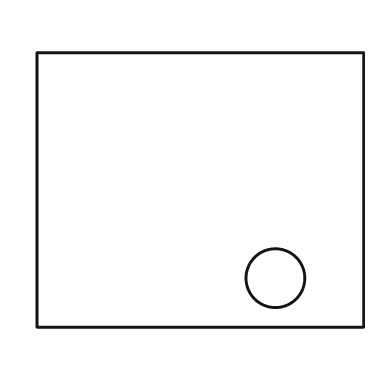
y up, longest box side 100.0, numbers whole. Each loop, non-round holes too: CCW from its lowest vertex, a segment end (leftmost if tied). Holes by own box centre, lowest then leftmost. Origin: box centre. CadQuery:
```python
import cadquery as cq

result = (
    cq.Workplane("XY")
    .moveTo(-50.0, -42.0)
    .lineTo(50.0, -42.0)
    .lineTo(50.0, 42.0)
    .lineTo(-50.0, 42.0)
    .close()
    .moveTo(23.0, -27.0)
    .circle(9.0)
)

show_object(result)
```